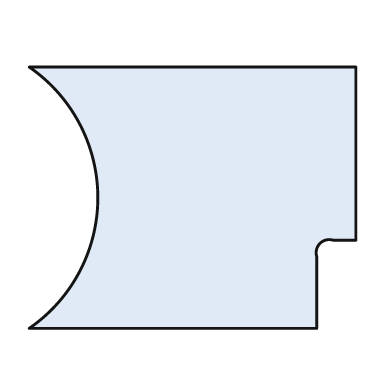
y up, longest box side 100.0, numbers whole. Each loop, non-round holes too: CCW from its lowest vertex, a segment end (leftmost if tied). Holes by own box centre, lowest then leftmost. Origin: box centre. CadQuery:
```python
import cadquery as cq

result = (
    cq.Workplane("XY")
    .moveTo(-50.0, -40.0)
    .lineTo(38.0, -40.0)
    .lineTo(38.0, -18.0)
    .threePointArc((39.0, -14.0), (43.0, -13.0))
    .lineTo(50.0, -13.0)
    .lineTo(50.0, 40.0)
    .lineTo(-50.0, 40.0)
    .threePointArc((-29.0, 0.0), (-50.0, -40.0))
    .close()
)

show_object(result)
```